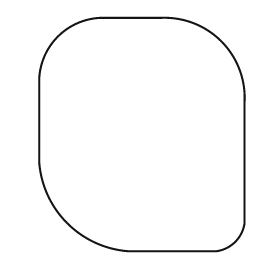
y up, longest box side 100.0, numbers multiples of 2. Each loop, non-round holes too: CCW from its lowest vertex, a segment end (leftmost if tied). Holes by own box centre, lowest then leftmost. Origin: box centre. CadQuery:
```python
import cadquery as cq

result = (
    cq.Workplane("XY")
    .moveTo(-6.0, -50.0)
    .lineTo(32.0, -50.0)
    .threePointArc((40.0, -46.0), (44.0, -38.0))
    .lineTo(44.0, 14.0)
    .threePointArc((34.0, 40.0), (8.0, 50.0))
    .lineTo(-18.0, 50.0)
    .threePointArc((-36.0, 42.0), (-44.0, 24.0))
    .lineTo(-44.0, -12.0)
    .threePointArc((-32.0, -38.0), (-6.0, -50.0))
    .close()
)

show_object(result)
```